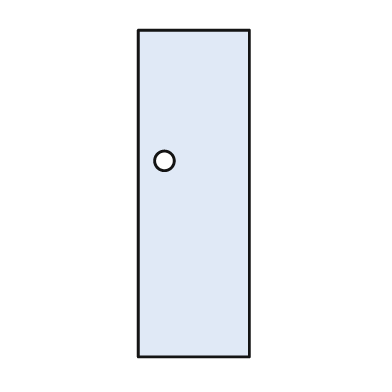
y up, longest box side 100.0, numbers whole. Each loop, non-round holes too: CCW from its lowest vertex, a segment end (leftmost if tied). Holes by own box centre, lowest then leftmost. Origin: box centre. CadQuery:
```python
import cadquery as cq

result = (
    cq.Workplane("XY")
    .moveTo(-17.0, -50.0)
    .lineTo(17.0, -50.0)
    .lineTo(17.0, 50.0)
    .lineTo(-17.0, 50.0)
    .close()
    .moveTo(-9.0, 10.0)
    .circle(3.0)
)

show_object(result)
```